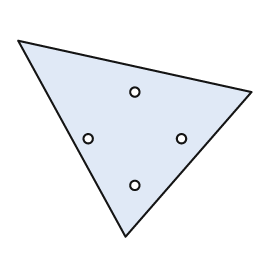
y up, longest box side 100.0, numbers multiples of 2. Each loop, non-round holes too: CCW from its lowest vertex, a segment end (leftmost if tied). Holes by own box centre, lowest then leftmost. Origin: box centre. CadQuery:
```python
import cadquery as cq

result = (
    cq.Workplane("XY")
    .moveTo(-4.0, -42.0)
    .lineTo(50.0, 20.0)
    .lineTo(-50.0, 42.0)
    .close()
    .moveTo(0.0, -20.0)
    .circle(2.0)
    .moveTo(-20.0, 0.0)
    .circle(2.0)
    .moveTo(20.0, 0.0)
    .circle(2.0)
    .moveTo(0.0, 20.0)
    .circle(2.0)
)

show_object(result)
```